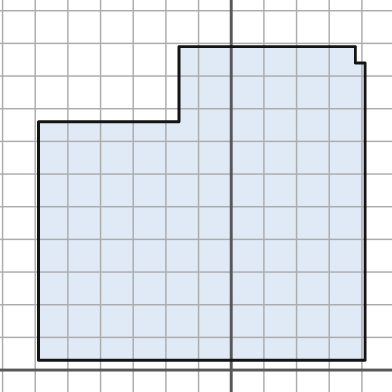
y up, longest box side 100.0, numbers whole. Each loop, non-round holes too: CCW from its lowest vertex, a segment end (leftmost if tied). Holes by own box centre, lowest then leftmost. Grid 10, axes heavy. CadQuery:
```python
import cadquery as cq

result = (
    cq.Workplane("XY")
    .moveTo(-59.0, 3.0)
    .lineTo(41.0, 3.0)
    .lineTo(41.0, 94.0)
    .lineTo(38.0, 94.0)
    .lineTo(38.0, 99.0)
    .lineTo(-16.0, 99.0)
    .lineTo(-16.0, 76.0)
    .lineTo(-59.0, 76.0)
    .close()
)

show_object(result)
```